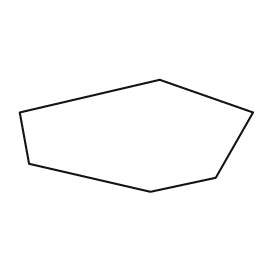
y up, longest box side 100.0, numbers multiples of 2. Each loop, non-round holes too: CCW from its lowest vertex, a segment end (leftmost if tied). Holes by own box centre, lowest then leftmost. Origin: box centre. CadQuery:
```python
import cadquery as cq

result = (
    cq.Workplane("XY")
    .moveTo(6.0, -24.0)
    .lineTo(34.0, -18.0)
    .lineTo(50.0, 10.0)
    .lineTo(10.0, 24.0)
    .lineTo(-50.0, 10.0)
    .lineTo(-46.0, -12.0)
    .close()
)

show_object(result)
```